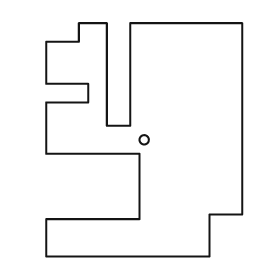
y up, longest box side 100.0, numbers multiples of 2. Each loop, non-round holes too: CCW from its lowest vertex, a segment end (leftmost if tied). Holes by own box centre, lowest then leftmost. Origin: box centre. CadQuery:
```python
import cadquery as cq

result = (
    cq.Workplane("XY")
    .moveTo(-42.0, -50.0)
    .lineTo(28.0, -50.0)
    .lineTo(28.0, -32.0)
    .lineTo(42.0, -32.0)
    .lineTo(42.0, 50.0)
    .lineTo(-6.0, 50.0)
    .lineTo(-6.0, 6.0)
    .lineTo(-16.0, 6.0)
    .lineTo(-16.0, 50.0)
    .lineTo(-28.0, 50.0)
    .lineTo(-28.0, 42.0)
    .lineTo(-42.0, 42.0)
    .lineTo(-42.0, 24.0)
    .lineTo(-24.0, 24.0)
    .lineTo(-24.0, 16.0)
    .lineTo(-42.0, 16.0)
    .lineTo(-42.0, -6.0)
    .lineTo(-2.0, -6.0)
    .lineTo(-2.0, -34.0)
    .lineTo(-42.0, -34.0)
    .close()
    .moveTo(0.0, 0.0)
    .circle(2.0)
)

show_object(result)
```